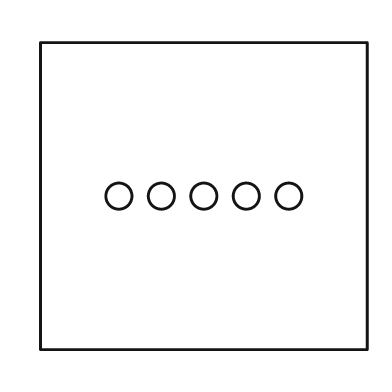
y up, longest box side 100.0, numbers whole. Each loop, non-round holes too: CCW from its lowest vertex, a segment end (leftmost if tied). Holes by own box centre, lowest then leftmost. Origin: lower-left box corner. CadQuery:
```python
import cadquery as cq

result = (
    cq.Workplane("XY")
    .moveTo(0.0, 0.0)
    .lineTo(100.0, 0.0)
    .lineTo(100.0, 94.0)
    .lineTo(0.0, 94.0)
    .close()
    .moveTo(24.0, 47.0)
    .circle(4.0)
    .moveTo(37.0, 47.0)
    .circle(4.0)
    .moveTo(50.0, 47.0)
    .circle(4.0)
    .moveTo(63.0, 47.0)
    .circle(4.0)
    .moveTo(76.0, 47.0)
    .circle(4.0)
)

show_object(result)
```